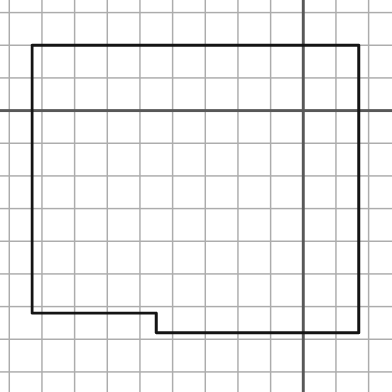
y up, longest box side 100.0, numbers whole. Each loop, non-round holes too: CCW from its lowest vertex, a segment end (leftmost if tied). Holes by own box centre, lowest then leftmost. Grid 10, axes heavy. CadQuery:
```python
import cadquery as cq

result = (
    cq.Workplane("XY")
    .moveTo(-45.0, -68.0)
    .lineTo(17.0, -68.0)
    .lineTo(17.0, 20.0)
    .lineTo(-83.0, 20.0)
    .lineTo(-83.0, -62.0)
    .lineTo(-45.0, -62.0)
    .close()
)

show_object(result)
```